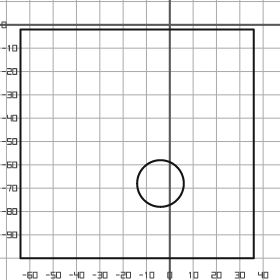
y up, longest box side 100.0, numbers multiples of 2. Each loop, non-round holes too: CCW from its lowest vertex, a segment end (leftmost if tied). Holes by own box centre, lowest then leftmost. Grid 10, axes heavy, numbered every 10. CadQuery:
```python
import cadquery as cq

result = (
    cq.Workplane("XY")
    .moveTo(-64.0, -100.0)
    .lineTo(36.0, -100.0)
    .lineTo(36.0, -2.0)
    .lineTo(-64.0, -2.0)
    .close()
    .moveTo(-4.0, -68.0)
    .circle(10.0)
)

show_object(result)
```